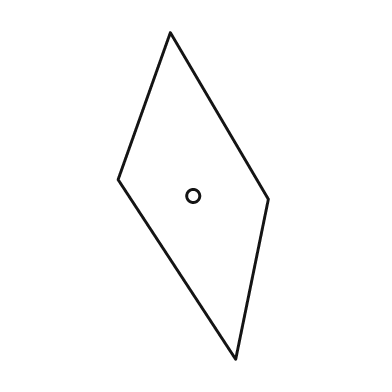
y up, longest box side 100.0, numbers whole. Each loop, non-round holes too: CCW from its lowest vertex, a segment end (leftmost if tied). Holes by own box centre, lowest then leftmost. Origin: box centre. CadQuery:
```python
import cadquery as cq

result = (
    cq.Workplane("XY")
    .moveTo(13.0, -50.0)
    .lineTo(23.0, -1.0)
    .lineTo(-7.0, 50.0)
    .lineTo(-23.0, 5.0)
    .close()
    .moveTo(0.0, 0.0)
    .circle(2.0)
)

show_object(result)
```